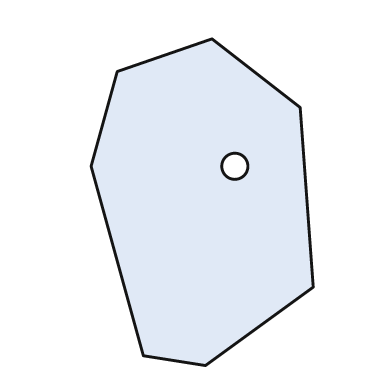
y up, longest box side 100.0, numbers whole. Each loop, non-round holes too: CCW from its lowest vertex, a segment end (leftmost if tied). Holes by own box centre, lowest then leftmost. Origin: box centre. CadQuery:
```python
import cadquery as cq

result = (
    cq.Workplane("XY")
    .moveTo(1.0, -50.0)
    .lineTo(34.0, -26.0)
    .lineTo(30.0, 29.0)
    .lineTo(3.0, 50.0)
    .lineTo(-26.0, 40.0)
    .lineTo(-34.0, 11.0)
    .lineTo(-18.0, -47.0)
    .close()
    .moveTo(10.0, 11.0)
    .circle(4.0)
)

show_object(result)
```